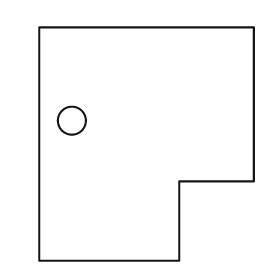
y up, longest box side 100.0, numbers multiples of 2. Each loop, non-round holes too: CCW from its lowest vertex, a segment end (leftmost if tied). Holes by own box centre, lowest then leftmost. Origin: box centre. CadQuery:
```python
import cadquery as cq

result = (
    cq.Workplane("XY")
    .moveTo(-46.0, -50.0)
    .lineTo(14.0, -50.0)
    .lineTo(14.0, -16.0)
    .lineTo(46.0, -16.0)
    .lineTo(46.0, 50.0)
    .lineTo(-46.0, 50.0)
    .close()
    .moveTo(-32.0, 10.0)
    .circle(6.0)
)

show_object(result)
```